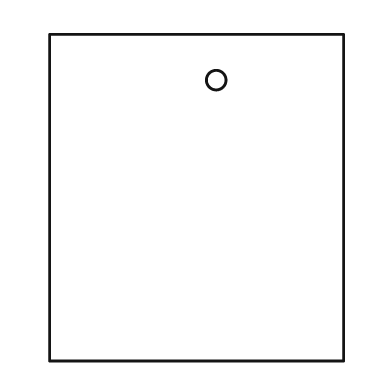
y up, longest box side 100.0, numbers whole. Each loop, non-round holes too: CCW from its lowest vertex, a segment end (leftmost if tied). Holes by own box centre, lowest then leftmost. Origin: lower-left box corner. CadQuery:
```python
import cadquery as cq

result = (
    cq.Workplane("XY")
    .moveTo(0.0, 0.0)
    .lineTo(90.0, 0.0)
    .lineTo(90.0, 100.0)
    .lineTo(0.0, 100.0)
    .close()
    .moveTo(51.0, 86.0)
    .circle(3.0)
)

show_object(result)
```